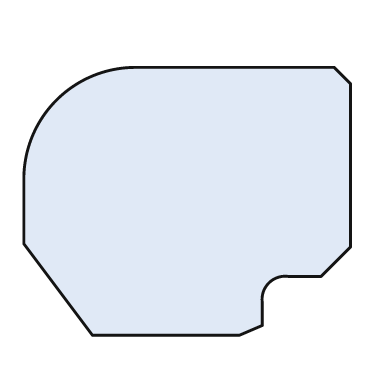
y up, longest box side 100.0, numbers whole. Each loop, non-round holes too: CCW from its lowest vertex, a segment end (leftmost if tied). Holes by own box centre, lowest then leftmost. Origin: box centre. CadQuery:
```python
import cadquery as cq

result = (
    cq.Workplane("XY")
    .moveTo(-29.0, -41.0)
    .lineTo(16.0, -41.0)
    .lineTo(23.0, -38.0)
    .lineTo(23.0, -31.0)
    .threePointArc((25.0, -25.0), (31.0, -23.0))
    .lineTo(41.0, -23.0)
    .lineTo(50.0, -14.0)
    .lineTo(50.0, 36.0)
    .lineTo(45.0, 41.0)
    .lineTo(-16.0, 41.0)
    .threePointArc((-40.0, 31.0), (-50.0, 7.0))
    .lineTo(-50.0, -13.0)
    .close()
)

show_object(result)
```